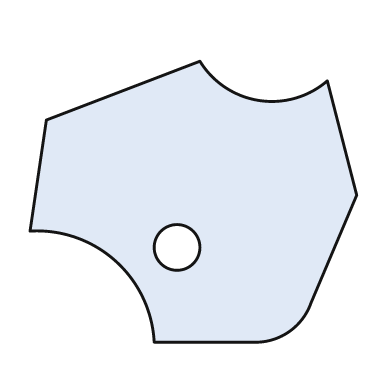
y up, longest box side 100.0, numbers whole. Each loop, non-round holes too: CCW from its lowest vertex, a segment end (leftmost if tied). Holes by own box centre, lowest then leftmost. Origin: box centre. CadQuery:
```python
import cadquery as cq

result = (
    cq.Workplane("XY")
    .moveTo(-12.0, -43.0)
    .lineTo(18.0, -43.0)
    .threePointArc((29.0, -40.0), (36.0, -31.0))
    .lineTo(50.0, 2.0)
    .lineTo(41.0, 37.0)
    .threePointArc((20.0, 31.0), (2.0, 43.0))
    .lineTo(-45.0, 25.0)
    .lineTo(-50.0, -9.0)
    .threePointArc((-24.0, -18.0), (-12.0, -43.0))
    .close()
    .moveTo(-5.0, -14.0)
    .circle(7.0)
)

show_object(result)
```